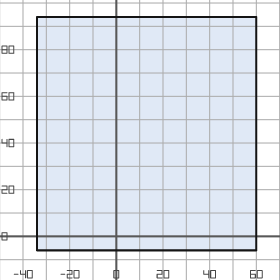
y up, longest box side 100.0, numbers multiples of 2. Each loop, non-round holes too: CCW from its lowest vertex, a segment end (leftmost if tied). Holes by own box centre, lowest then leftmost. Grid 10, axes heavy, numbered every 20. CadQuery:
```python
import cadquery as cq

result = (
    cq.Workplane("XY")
    .moveTo(-34.0, -6.0)
    .lineTo(60.0, -6.0)
    .lineTo(60.0, 94.0)
    .lineTo(-34.0, 94.0)
    .close()
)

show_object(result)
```